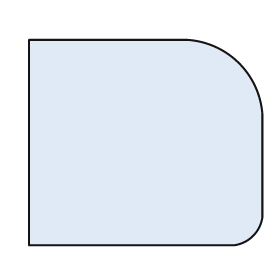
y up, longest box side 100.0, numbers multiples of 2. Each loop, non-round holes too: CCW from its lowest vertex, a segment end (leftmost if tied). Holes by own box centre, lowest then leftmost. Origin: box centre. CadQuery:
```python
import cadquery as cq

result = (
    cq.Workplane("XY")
    .moveTo(-50.0, -44.0)
    .lineTo(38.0, -44.0)
    .threePointArc((46.0, -40.0), (50.0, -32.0))
    .lineTo(50.0, 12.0)
    .threePointArc((40.0, 34.0), (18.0, 44.0))
    .lineTo(-50.0, 44.0)
    .close()
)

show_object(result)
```